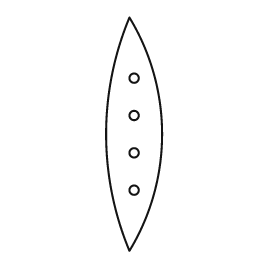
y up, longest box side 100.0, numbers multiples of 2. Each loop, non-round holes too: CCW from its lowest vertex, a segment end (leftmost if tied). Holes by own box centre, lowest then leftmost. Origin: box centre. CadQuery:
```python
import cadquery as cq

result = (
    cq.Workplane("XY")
    .moveTo(-2.0, -50.0)
    .threePointArc((12.0, 0.0), (-2.0, 50.0))
    .threePointArc((-12.0, 0.0), (-2.0, -50.0))
    .close()
    .moveTo(0.0, -24.0)
    .circle(2.0)
    .moveTo(0.0, -8.0)
    .circle(2.0)
    .moveTo(0.0, 8.0)
    .circle(2.0)
    .moveTo(0.0, 24.0)
    .circle(2.0)
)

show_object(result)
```